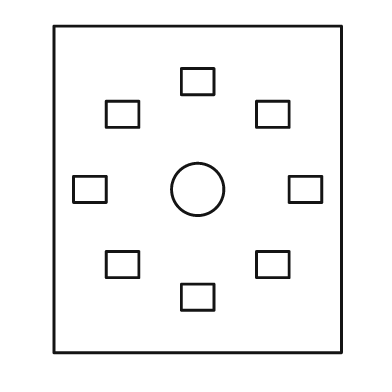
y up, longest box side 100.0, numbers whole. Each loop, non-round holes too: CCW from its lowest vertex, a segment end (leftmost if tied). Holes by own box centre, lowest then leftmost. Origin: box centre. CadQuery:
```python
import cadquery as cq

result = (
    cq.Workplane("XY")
    .moveTo(-44.0, -50.0)
    .lineTo(44.0, -50.0)
    .lineTo(44.0, 50.0)
    .lineTo(-44.0, 50.0)
    .close()
    .moveTo(-5.0, -37.0)
    .lineTo(5.0, -37.0)
    .lineTo(5.0, -29.0)
    .lineTo(-5.0, -29.0)
    .close()
    .moveTo(-28.0, -27.0)
    .lineTo(-18.0, -27.0)
    .lineTo(-18.0, -19.0)
    .lineTo(-28.0, -19.0)
    .close()
    .moveTo(18.0, -27.0)
    .lineTo(28.0, -27.0)
    .lineTo(28.0, -19.0)
    .lineTo(18.0, -19.0)
    .close()
    .moveTo(-38.0, -4.0)
    .lineTo(-28.0, -4.0)
    .lineTo(-28.0, 4.0)
    .lineTo(-38.0, 4.0)
    .close()
    .moveTo(0.0, 0.0)
    .circle(8.0)
    .moveTo(28.0, -4.0)
    .lineTo(38.0, -4.0)
    .lineTo(38.0, 4.0)
    .lineTo(28.0, 4.0)
    .close()
    .moveTo(-28.0, 19.0)
    .lineTo(-18.0, 19.0)
    .lineTo(-18.0, 27.0)
    .lineTo(-28.0, 27.0)
    .close()
    .moveTo(18.0, 19.0)
    .lineTo(28.0, 19.0)
    .lineTo(28.0, 27.0)
    .lineTo(18.0, 27.0)
    .close()
    .moveTo(-5.0, 29.0)
    .lineTo(5.0, 29.0)
    .lineTo(5.0, 37.0)
    .lineTo(-5.0, 37.0)
    .close()
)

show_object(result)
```